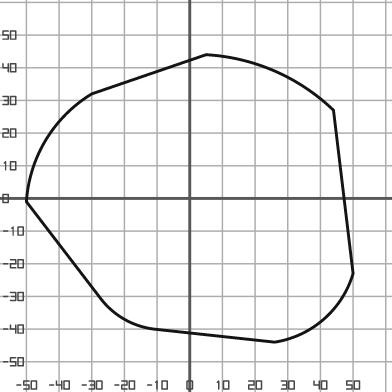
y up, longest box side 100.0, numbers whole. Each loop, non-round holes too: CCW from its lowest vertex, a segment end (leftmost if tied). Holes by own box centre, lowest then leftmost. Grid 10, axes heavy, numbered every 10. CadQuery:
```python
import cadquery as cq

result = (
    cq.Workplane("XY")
    .moveTo(26.0, -44.0)
    .threePointArc((41.0, -37.0), (50.0, -23.0))
    .lineTo(44.0, 27.0)
    .threePointArc((26.0, 39.0), (5.0, 44.0))
    .lineTo(-30.0, 32.0)
    .threePointArc((-44.0, 18.0), (-50.0, -1.0))
    .lineTo(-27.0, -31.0)
    .threePointArc((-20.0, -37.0), (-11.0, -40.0))
    .close()
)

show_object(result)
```